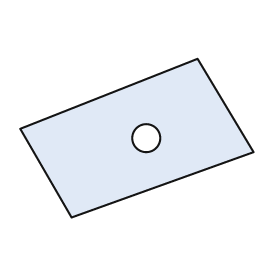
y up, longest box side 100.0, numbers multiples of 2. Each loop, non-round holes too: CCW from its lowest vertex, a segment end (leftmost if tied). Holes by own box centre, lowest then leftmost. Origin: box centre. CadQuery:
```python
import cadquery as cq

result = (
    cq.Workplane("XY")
    .moveTo(-28.0, -34.0)
    .lineTo(50.0, -6.0)
    .lineTo(26.0, 34.0)
    .lineTo(-50.0, 4.0)
    .close()
    .moveTo(4.0, 0.0)
    .circle(6.0)
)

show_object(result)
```